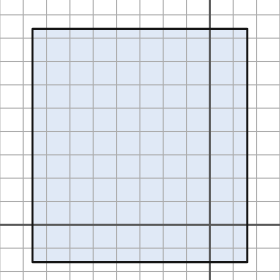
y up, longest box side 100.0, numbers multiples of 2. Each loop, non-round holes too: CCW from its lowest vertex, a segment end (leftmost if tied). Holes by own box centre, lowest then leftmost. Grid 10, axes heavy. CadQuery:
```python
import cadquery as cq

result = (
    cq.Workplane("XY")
    .moveTo(-76.0, -16.0)
    .lineTo(16.0, -16.0)
    .lineTo(16.0, 84.0)
    .lineTo(-76.0, 84.0)
    .close()
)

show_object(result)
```